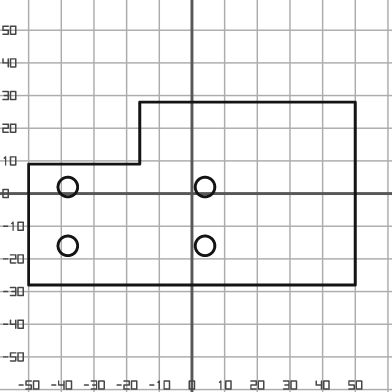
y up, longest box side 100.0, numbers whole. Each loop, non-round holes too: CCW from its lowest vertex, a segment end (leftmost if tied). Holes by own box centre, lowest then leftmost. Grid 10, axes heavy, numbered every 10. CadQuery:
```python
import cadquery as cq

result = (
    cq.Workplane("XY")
    .moveTo(-50.0, -28.0)
    .lineTo(50.0, -28.0)
    .lineTo(50.0, 28.0)
    .lineTo(-16.0, 28.0)
    .lineTo(-16.0, 9.0)
    .lineTo(-50.0, 9.0)
    .close()
    .moveTo(-38.0, -16.0)
    .circle(3.0)
    .moveTo(4.0, -16.0)
    .circle(3.0)
    .moveTo(-38.0, 2.0)
    .circle(3.0)
    .moveTo(4.0, 2.0)
    .circle(3.0)
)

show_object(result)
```